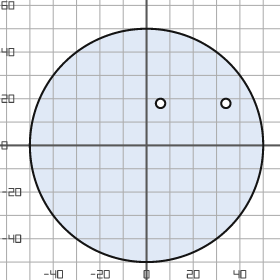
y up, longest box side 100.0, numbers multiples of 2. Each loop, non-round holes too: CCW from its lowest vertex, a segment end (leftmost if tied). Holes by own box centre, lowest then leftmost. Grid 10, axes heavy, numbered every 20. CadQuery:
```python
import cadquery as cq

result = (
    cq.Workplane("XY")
    .moveTo(0.0, 0.0)
    .circle(50.0)
    .moveTo(6.0, 18.0)
    .circle(2.0)
    .moveTo(34.0, 18.0)
    .circle(2.0)
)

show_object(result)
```